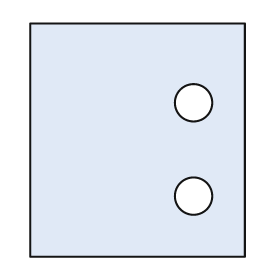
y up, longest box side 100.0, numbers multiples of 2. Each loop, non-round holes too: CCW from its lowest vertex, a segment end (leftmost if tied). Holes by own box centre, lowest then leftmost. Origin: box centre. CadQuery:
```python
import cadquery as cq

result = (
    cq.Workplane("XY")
    .moveTo(-46.0, -50.0)
    .lineTo(46.0, -50.0)
    .lineTo(46.0, 50.0)
    .lineTo(-46.0, 50.0)
    .close()
    .moveTo(24.0, -24.0)
    .circle(8.0)
    .moveTo(24.0, 16.0)
    .circle(8.0)
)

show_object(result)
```